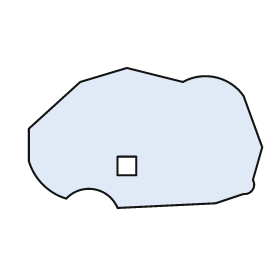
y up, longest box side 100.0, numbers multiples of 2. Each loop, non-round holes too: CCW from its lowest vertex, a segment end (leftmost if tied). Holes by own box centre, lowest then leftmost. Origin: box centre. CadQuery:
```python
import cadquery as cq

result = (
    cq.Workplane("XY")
    .moveTo(-12.0, -30.0)
    .lineTo(30.0, -28.0)
    .lineTo(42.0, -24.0)
    .threePointArc((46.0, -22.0), (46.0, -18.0))
    .lineTo(50.0, -4.0)
    .lineTo(42.0, 18.0)
    .threePointArc((30.0, 26.0), (16.0, 24.0))
    .lineTo(-8.0, 30.0)
    .lineTo(-28.0, 24.0)
    .lineTo(-50.0, 4.0)
    .lineTo(-50.0, -10.0)
    .threePointArc((-44.0, -20.0), (-34.0, -26.0))
    .threePointArc((-22.0, -22.0), (-12.0, -30.0))
    .close()
    .moveTo(-12.0, -16.0)
    .lineTo(-4.0, -16.0)
    .lineTo(-4.0, -8.0)
    .lineTo(-12.0, -8.0)
    .close()
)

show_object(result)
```